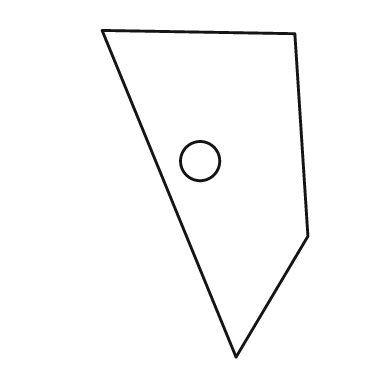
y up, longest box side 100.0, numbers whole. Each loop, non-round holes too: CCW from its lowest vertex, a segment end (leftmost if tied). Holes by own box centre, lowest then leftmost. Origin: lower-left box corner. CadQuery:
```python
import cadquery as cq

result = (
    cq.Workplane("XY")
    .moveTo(41.0, 0.0)
    .lineTo(63.0, 37.0)
    .lineTo(59.0, 99.0)
    .lineTo(0.0, 100.0)
    .close()
    .moveTo(30.0, 60.0)
    .circle(6.0)
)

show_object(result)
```